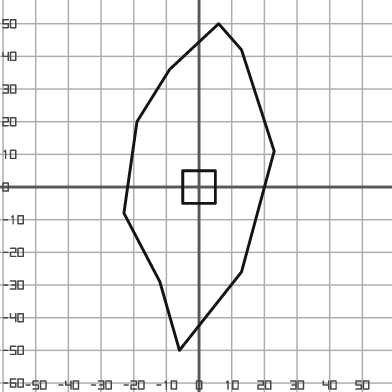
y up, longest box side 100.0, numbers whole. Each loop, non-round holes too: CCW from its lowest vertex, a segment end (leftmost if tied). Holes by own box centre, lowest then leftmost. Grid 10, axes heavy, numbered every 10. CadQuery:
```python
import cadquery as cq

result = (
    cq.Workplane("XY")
    .moveTo(-6.0, -50.0)
    .lineTo(13.0, -26.0)
    .lineTo(23.0, 11.0)
    .lineTo(13.0, 42.0)
    .lineTo(6.0, 50.0)
    .lineTo(-9.0, 36.0)
    .lineTo(-19.0, 20.0)
    .lineTo(-23.0, -8.0)
    .lineTo(-12.0, -29.0)
    .close()
    .moveTo(-5.0, -5.0)
    .lineTo(5.0, -5.0)
    .lineTo(5.0, 5.0)
    .lineTo(-5.0, 5.0)
    .close()
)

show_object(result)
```